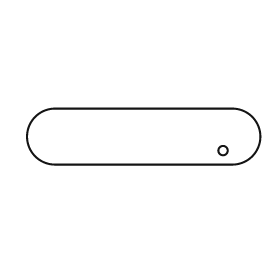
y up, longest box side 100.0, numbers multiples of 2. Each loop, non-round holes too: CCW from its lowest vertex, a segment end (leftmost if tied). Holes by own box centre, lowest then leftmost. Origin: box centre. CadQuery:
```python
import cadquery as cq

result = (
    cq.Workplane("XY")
    .moveTo(-38.0, -12.0)
    .lineTo(38.0, -12.0)
    .threePointArc((50.0, 0.0), (38.0, 12.0))
    .lineTo(-38.0, 12.0)
    .threePointArc((-50.0, 0.0), (-38.0, -12.0))
    .close()
    .moveTo(34.0, -6.0)
    .circle(2.0)
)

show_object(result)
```